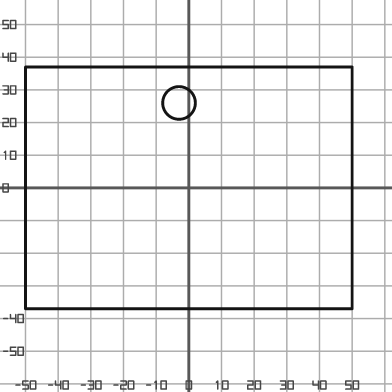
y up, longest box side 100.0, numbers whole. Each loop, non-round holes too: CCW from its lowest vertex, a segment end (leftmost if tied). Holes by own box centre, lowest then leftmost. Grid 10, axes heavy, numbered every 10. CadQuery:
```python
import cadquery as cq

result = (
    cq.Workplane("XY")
    .moveTo(-50.0, -37.0)
    .lineTo(50.0, -37.0)
    .lineTo(50.0, 37.0)
    .lineTo(-50.0, 37.0)
    .close()
    .moveTo(-3.0, 26.0)
    .circle(5.0)
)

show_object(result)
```